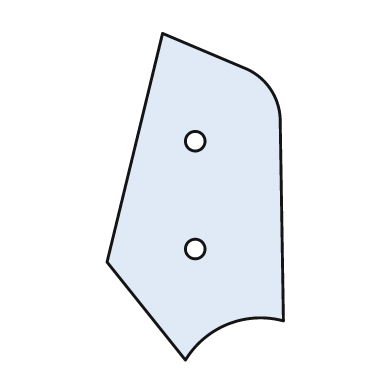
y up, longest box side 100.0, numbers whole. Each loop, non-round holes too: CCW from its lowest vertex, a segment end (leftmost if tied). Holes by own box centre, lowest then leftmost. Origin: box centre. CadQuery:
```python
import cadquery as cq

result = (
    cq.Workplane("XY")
    .moveTo(-3.0, -50.0)
    .threePointArc((10.0, -39.0), (27.0, -38.0))
    .lineTo(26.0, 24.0)
    .threePointArc((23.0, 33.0), (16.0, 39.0))
    .lineTo(-10.0, 50.0)
    .lineTo(-27.0, -20.0)
    .close()
    .moveTo(0.0, -16.0)
    .circle(3.0)
    .moveTo(0.0, 17.0)
    .circle(3.0)
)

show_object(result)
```